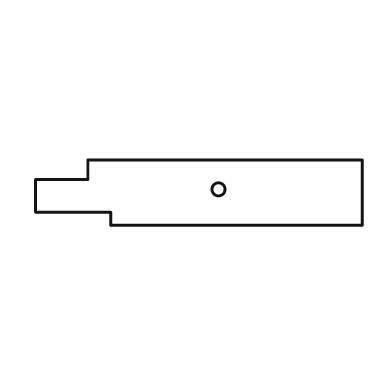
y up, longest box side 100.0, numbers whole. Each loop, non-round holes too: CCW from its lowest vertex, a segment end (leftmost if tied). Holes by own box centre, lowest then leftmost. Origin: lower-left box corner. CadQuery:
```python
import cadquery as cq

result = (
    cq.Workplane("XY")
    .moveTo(23.0, 0.0)
    .lineTo(100.0, 0.0)
    .lineTo(100.0, 20.0)
    .lineTo(16.0, 20.0)
    .lineTo(16.0, 14.0)
    .lineTo(0.0, 14.0)
    .lineTo(0.0, 4.0)
    .lineTo(23.0, 4.0)
    .close()
    .moveTo(56.0, 11.0)
    .circle(2.0)
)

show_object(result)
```